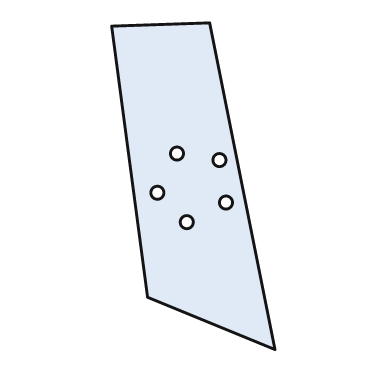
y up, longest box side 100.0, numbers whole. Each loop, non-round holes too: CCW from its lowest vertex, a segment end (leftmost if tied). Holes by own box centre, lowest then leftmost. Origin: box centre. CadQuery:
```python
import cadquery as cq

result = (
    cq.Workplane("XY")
    .moveTo(25.0, -50.0)
    .lineTo(5.0, 50.0)
    .lineTo(-25.0, 49.0)
    .lineTo(-14.0, -34.0)
    .close()
    .moveTo(-2.0, -11.0)
    .circle(2.0)
    .moveTo(10.0, -5.0)
    .circle(2.0)
    .moveTo(-11.0, -2.0)
    .circle(2.0)
    .moveTo(8.0, 8.0)
    .circle(2.0)
    .moveTo(-5.0, 10.0)
    .circle(2.0)
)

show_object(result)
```